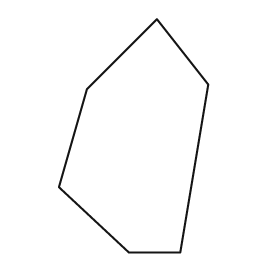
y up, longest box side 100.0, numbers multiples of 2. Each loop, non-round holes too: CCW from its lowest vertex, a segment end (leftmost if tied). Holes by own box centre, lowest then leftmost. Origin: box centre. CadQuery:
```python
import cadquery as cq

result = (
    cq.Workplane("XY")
    .moveTo(-2.0, -50.0)
    .lineTo(20.0, -50.0)
    .lineTo(32.0, 22.0)
    .lineTo(10.0, 50.0)
    .lineTo(-20.0, 20.0)
    .lineTo(-32.0, -22.0)
    .close()
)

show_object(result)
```